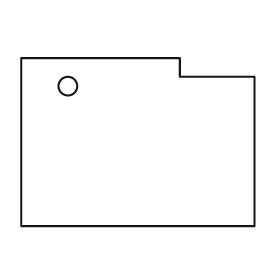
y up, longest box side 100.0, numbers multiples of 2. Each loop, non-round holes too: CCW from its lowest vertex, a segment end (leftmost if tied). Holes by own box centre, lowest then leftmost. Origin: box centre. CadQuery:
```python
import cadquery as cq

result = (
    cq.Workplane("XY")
    .moveTo(-50.0, -36.0)
    .lineTo(50.0, -36.0)
    .lineTo(50.0, 28.0)
    .lineTo(18.0, 28.0)
    .lineTo(18.0, 36.0)
    .lineTo(-50.0, 36.0)
    .close()
    .moveTo(-30.0, 24.0)
    .circle(4.0)
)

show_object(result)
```